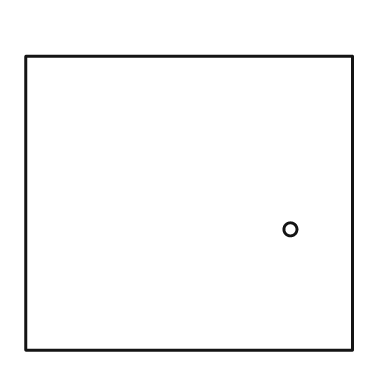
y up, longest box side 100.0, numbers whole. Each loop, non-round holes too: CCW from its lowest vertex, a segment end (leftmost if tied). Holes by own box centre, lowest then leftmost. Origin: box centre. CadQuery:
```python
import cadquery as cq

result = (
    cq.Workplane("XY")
    .moveTo(-50.0, -45.0)
    .lineTo(50.0, -45.0)
    .lineTo(50.0, 45.0)
    .lineTo(-50.0, 45.0)
    .close()
    .moveTo(31.0, -8.0)
    .circle(2.0)
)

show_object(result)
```